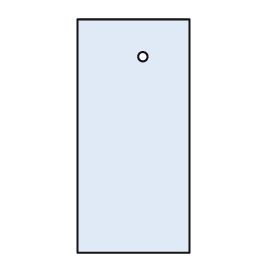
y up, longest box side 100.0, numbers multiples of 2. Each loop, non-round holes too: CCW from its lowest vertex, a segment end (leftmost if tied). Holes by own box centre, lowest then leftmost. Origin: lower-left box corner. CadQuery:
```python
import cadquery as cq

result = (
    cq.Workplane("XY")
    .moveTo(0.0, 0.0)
    .lineTo(48.0, 0.0)
    .lineTo(48.0, 100.0)
    .lineTo(0.0, 100.0)
    .close()
    .moveTo(28.0, 84.0)
    .circle(2.0)
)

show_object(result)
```